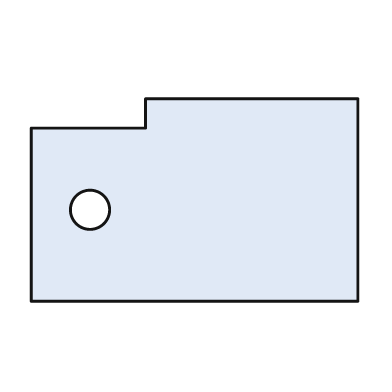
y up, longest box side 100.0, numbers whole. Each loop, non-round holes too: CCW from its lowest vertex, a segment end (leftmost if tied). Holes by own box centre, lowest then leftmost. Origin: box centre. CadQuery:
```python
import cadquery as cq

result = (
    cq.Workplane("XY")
    .moveTo(-50.0, -31.0)
    .lineTo(50.0, -31.0)
    .lineTo(50.0, 31.0)
    .lineTo(-15.0, 31.0)
    .lineTo(-15.0, 22.0)
    .lineTo(-50.0, 22.0)
    .close()
    .moveTo(-32.0, -3.0)
    .circle(6.0)
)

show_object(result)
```